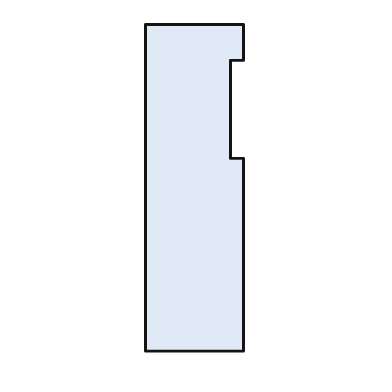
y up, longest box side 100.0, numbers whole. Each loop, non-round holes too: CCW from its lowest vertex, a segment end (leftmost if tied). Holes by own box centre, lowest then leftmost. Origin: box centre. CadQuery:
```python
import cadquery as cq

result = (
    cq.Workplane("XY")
    .moveTo(-15.0, -50.0)
    .lineTo(15.0, -50.0)
    .lineTo(15.0, 9.0)
    .lineTo(11.0, 9.0)
    .lineTo(11.0, 39.0)
    .lineTo(15.0, 39.0)
    .lineTo(15.0, 50.0)
    .lineTo(-15.0, 50.0)
    .close()
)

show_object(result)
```